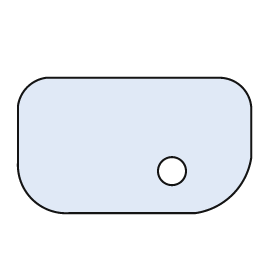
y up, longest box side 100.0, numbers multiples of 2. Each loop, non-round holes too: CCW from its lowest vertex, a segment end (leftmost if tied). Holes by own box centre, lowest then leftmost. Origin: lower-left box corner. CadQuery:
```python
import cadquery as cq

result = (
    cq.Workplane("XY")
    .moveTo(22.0, 0.0)
    .lineTo(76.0, 0.0)
    .threePointArc((92.0, 8.0), (100.0, 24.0))
    .lineTo(100.0, 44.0)
    .threePointArc((96.0, 54.0), (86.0, 58.0))
    .lineTo(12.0, 58.0)
    .threePointArc((4.0, 54.0), (0.0, 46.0))
    .lineTo(0.0, 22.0)
    .threePointArc((6.0, 6.0), (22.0, 0.0))
    .close()
    .moveTo(66.0, 18.0)
    .circle(6.0)
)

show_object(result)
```